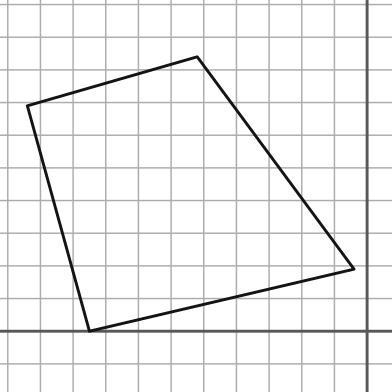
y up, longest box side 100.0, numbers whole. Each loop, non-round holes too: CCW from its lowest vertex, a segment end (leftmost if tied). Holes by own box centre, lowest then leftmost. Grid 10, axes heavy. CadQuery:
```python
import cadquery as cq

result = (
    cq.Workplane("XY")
    .moveTo(-85.0, 0.0)
    .lineTo(-4.0, 19.0)
    .lineTo(-52.0, 84.0)
    .lineTo(-104.0, 69.0)
    .close()
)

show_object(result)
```